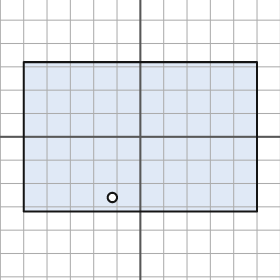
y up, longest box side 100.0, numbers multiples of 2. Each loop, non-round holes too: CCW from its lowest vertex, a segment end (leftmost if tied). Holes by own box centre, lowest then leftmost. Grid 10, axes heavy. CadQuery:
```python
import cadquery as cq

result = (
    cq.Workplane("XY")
    .moveTo(-50.0, -32.0)
    .lineTo(50.0, -32.0)
    .lineTo(50.0, 32.0)
    .lineTo(-50.0, 32.0)
    .close()
    .moveTo(-12.0, -26.0)
    .circle(2.0)
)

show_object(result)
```